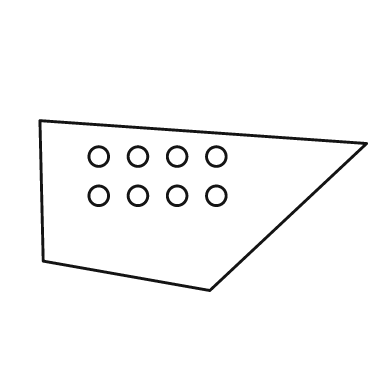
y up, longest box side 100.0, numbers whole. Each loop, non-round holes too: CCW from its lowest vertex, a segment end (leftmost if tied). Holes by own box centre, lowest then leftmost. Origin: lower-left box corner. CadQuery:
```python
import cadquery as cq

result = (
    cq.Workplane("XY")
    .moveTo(52.0, 0.0)
    .lineTo(100.0, 45.0)
    .lineTo(0.0, 52.0)
    .lineTo(1.0, 9.0)
    .close()
    .moveTo(18.0, 29.0)
    .circle(3.0)
    .moveTo(30.0, 29.0)
    .circle(3.0)
    .moveTo(42.0, 29.0)
    .circle(3.0)
    .moveTo(54.0, 29.0)
    .circle(3.0)
    .moveTo(18.0, 41.0)
    .circle(3.0)
    .moveTo(30.0, 41.0)
    .circle(3.0)
    .moveTo(42.0, 41.0)
    .circle(3.0)
    .moveTo(54.0, 41.0)
    .circle(3.0)
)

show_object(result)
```